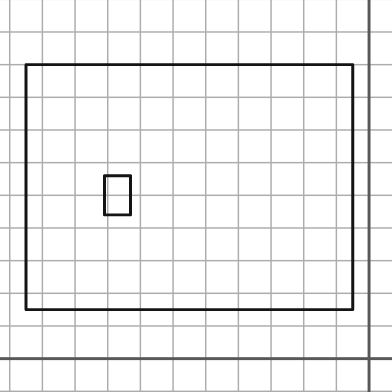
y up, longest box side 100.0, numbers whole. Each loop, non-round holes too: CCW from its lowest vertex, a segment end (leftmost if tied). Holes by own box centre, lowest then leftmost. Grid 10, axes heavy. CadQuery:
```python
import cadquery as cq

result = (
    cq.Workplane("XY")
    .moveTo(-105.0, 15.0)
    .lineTo(-5.0, 15.0)
    .lineTo(-5.0, 90.0)
    .lineTo(-105.0, 90.0)
    .close()
    .moveTo(-81.0, 44.0)
    .lineTo(-73.0, 44.0)
    .lineTo(-73.0, 56.0)
    .lineTo(-81.0, 56.0)
    .close()
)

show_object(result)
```